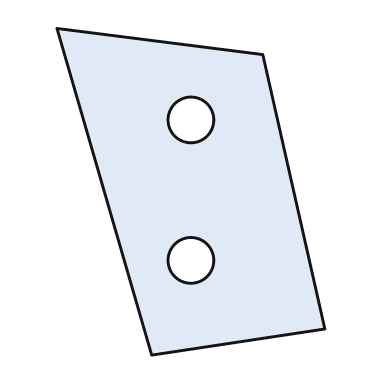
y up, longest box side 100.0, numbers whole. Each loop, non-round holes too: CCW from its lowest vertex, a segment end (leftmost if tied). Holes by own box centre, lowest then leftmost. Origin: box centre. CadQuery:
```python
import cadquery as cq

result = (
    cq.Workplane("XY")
    .moveTo(-12.0, -50.0)
    .lineTo(41.0, -42.0)
    .lineTo(22.0, 42.0)
    .lineTo(-41.0, 50.0)
    .close()
    .moveTo(0.0, -21.0)
    .circle(7.0)
    .moveTo(0.0, 22.0)
    .circle(7.0)
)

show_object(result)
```